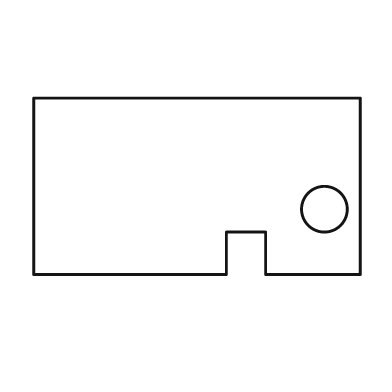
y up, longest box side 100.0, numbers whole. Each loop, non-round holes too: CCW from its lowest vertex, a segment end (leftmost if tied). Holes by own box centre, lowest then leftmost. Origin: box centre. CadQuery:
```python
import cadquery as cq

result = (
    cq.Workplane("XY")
    .moveTo(-50.0, -27.0)
    .lineTo(9.0, -27.0)
    .lineTo(9.0, -14.0)
    .lineTo(21.0, -14.0)
    .lineTo(21.0, -27.0)
    .lineTo(50.0, -27.0)
    .lineTo(50.0, 27.0)
    .lineTo(-50.0, 27.0)
    .close()
    .moveTo(39.0, -7.0)
    .circle(7.0)
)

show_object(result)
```